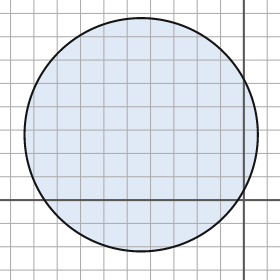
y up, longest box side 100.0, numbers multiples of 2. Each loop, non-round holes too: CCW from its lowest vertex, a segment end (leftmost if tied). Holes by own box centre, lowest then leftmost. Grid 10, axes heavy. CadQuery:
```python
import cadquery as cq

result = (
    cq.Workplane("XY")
    .moveTo(-44.0, 28.0)
    .circle(50.0)
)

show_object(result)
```